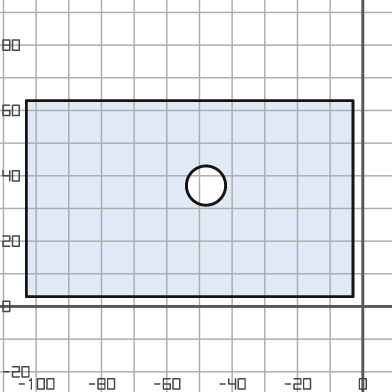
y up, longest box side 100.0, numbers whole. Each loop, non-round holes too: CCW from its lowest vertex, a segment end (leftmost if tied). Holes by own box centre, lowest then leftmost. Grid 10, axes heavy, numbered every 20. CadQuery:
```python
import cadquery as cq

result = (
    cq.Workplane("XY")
    .moveTo(-103.0, 3.0)
    .lineTo(-3.0, 3.0)
    .lineTo(-3.0, 63.0)
    .lineTo(-103.0, 63.0)
    .close()
    .moveTo(-48.0, 37.0)
    .circle(6.0)
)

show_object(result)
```